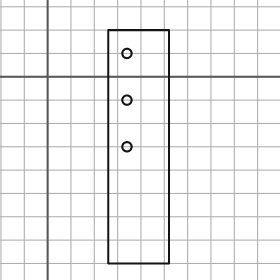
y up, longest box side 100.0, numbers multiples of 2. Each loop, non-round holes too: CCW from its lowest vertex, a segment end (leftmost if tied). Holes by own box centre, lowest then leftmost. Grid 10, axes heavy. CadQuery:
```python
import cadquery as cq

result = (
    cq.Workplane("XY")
    .moveTo(26.0, -80.0)
    .lineTo(52.0, -80.0)
    .lineTo(52.0, 20.0)
    .lineTo(26.0, 20.0)
    .close()
    .moveTo(34.0, -30.0)
    .circle(2.0)
    .moveTo(34.0, -10.0)
    .circle(2.0)
    .moveTo(34.0, 10.0)
    .circle(2.0)
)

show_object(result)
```